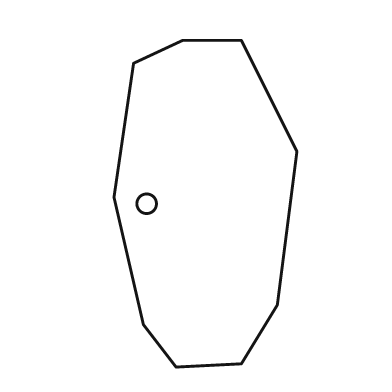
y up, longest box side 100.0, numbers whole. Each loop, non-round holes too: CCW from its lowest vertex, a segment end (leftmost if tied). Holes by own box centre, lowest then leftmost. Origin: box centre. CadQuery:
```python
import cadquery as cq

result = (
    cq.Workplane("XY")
    .moveTo(-9.0, -50.0)
    .lineTo(11.0, -49.0)
    .lineTo(22.0, -31.0)
    .lineTo(28.0, 16.0)
    .lineTo(11.0, 50.0)
    .lineTo(-7.0, 50.0)
    .lineTo(-22.0, 43.0)
    .lineTo(-28.0, 2.0)
    .lineTo(-19.0, -37.0)
    .close()
    .moveTo(-18.0, 0.0)
    .circle(3.0)
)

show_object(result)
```